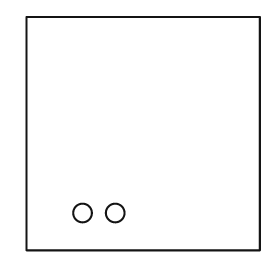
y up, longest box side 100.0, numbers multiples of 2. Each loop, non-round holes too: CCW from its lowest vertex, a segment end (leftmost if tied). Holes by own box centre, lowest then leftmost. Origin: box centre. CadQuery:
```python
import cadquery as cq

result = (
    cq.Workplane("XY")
    .moveTo(-50.0, -50.0)
    .lineTo(50.0, -50.0)
    .lineTo(50.0, 50.0)
    .lineTo(-50.0, 50.0)
    .close()
    .moveTo(-26.0, -34.0)
    .circle(4.0)
    .moveTo(-12.0, -34.0)
    .circle(4.0)
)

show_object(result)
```